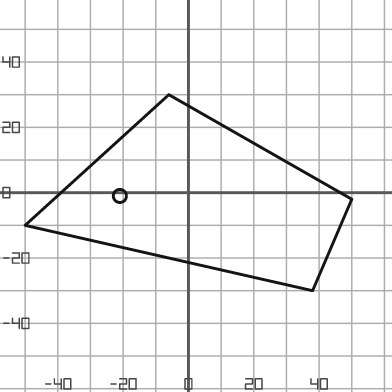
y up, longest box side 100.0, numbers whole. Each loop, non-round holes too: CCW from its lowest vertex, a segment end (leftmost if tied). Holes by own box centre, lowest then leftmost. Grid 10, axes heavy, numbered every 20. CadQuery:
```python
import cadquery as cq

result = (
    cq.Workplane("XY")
    .moveTo(38.0, -30.0)
    .lineTo(50.0, -2.0)
    .lineTo(-6.0, 30.0)
    .lineTo(-50.0, -10.0)
    .close()
    .moveTo(-21.0, -1.0)
    .circle(2.0)
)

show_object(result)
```